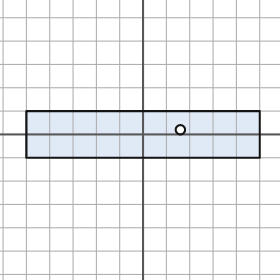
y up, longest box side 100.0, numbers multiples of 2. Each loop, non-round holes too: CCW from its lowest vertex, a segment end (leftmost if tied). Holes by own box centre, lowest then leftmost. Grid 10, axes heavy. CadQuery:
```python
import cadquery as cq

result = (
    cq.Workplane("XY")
    .moveTo(-50.0, -10.0)
    .lineTo(50.0, -10.0)
    .lineTo(50.0, 10.0)
    .lineTo(-50.0, 10.0)
    .close()
    .moveTo(16.0, 2.0)
    .circle(2.0)
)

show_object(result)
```